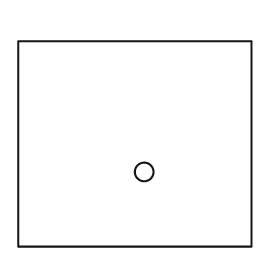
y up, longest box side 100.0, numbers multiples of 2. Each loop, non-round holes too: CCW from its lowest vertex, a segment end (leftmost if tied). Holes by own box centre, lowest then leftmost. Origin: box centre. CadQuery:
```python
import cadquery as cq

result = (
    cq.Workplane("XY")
    .moveTo(-50.0, -44.0)
    .lineTo(50.0, -44.0)
    .lineTo(50.0, 44.0)
    .lineTo(-50.0, 44.0)
    .close()
    .moveTo(4.0, -12.0)
    .circle(4.0)
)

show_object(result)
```